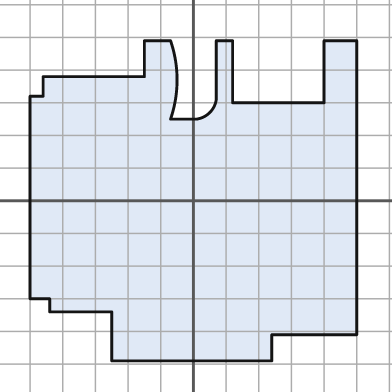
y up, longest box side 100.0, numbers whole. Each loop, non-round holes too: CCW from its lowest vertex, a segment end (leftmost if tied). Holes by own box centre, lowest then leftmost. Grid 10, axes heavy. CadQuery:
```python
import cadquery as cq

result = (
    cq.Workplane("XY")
    .moveTo(-25.0, -49.0)
    .lineTo(24.0, -49.0)
    .lineTo(24.0, -41.0)
    .lineTo(50.0, -41.0)
    .lineTo(50.0, 49.0)
    .lineTo(40.0, 49.0)
    .lineTo(40.0, 30.0)
    .lineTo(12.0, 30.0)
    .lineTo(12.0, 49.0)
    .lineTo(7.0, 49.0)
    .lineTo(7.0, 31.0)
    .threePointArc((5.0, 27.0), (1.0, 25.0))
    .lineTo(-7.0, 25.0)
    .threePointArc((-5.0, 37.0), (-7.0, 49.0))
    .lineTo(-15.0, 49.0)
    .lineTo(-15.0, 38.0)
    .lineTo(-46.0, 38.0)
    .lineTo(-46.0, 32.0)
    .lineTo(-50.0, 32.0)
    .lineTo(-50.0, -30.0)
    .lineTo(-44.0, -30.0)
    .lineTo(-44.0, -34.0)
    .lineTo(-25.0, -34.0)
    .close()
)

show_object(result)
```